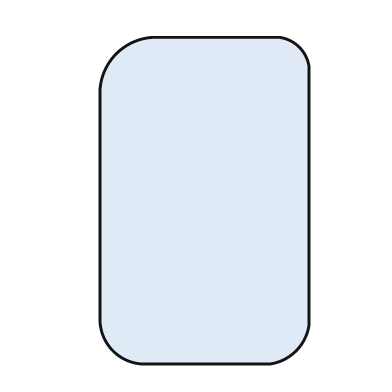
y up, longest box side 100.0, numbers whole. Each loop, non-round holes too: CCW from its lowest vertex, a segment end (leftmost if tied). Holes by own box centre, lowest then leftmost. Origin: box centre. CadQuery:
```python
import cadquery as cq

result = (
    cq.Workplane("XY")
    .moveTo(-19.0, -50.0)
    .lineTo(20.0, -50.0)
    .threePointArc((28.0, -46.0), (32.0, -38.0))
    .lineTo(32.0, 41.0)
    .threePointArc((29.0, 47.0), (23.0, 50.0))
    .lineTo(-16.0, 50.0)
    .threePointArc((-27.0, 45.0), (-32.0, 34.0))
    .lineTo(-32.0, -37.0)
    .threePointArc((-28.0, -46.0), (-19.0, -50.0))
    .close()
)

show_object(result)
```